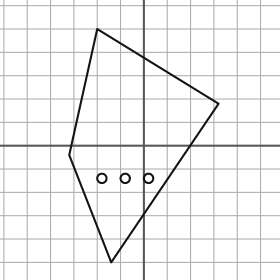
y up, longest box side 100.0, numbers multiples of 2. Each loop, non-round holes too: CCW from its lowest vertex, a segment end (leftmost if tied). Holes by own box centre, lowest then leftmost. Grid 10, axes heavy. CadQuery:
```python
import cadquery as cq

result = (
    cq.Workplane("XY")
    .moveTo(-14.0, -50.0)
    .lineTo(32.0, 18.0)
    .lineTo(-20.0, 50.0)
    .lineTo(-32.0, -4.0)
    .close()
    .moveTo(-18.0, -14.0)
    .circle(2.0)
    .moveTo(-8.0, -14.0)
    .circle(2.0)
    .moveTo(2.0, -14.0)
    .circle(2.0)
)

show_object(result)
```